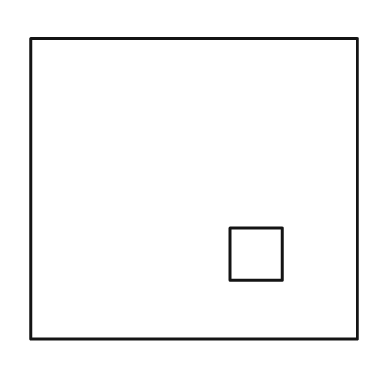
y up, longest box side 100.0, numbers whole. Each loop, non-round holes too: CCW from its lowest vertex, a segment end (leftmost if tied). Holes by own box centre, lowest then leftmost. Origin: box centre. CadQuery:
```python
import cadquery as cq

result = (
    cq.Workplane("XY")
    .moveTo(-50.0, -46.0)
    .lineTo(50.0, -46.0)
    .lineTo(50.0, 46.0)
    .lineTo(-50.0, 46.0)
    .close()
    .moveTo(11.0, -28.0)
    .lineTo(27.0, -28.0)
    .lineTo(27.0, -12.0)
    .lineTo(11.0, -12.0)
    .close()
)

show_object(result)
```